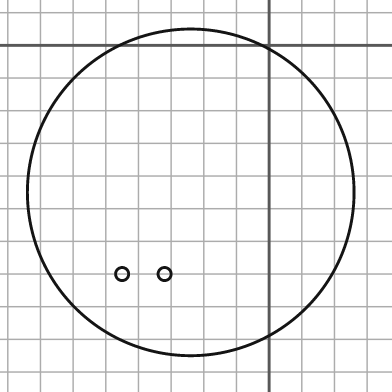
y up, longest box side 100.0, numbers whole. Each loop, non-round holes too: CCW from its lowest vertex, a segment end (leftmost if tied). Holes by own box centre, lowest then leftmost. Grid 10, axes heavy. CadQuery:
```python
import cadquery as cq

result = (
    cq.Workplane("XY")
    .moveTo(-24.0, -45.0)
    .circle(50.0)
    .moveTo(-45.0, -70.0)
    .circle(2.0)
    .moveTo(-32.0, -70.0)
    .circle(2.0)
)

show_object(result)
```